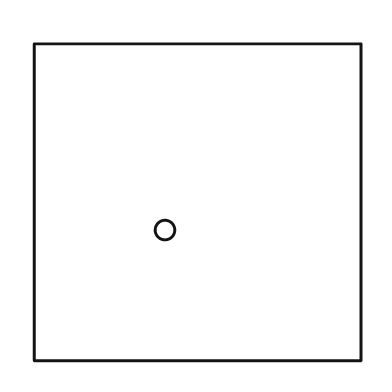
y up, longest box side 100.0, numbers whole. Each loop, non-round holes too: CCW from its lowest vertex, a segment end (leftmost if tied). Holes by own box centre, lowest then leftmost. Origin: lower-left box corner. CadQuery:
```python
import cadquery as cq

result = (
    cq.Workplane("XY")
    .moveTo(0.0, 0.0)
    .lineTo(100.0, 0.0)
    .lineTo(100.0, 97.0)
    .lineTo(0.0, 97.0)
    .close()
    .moveTo(40.0, 40.0)
    .circle(3.0)
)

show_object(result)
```